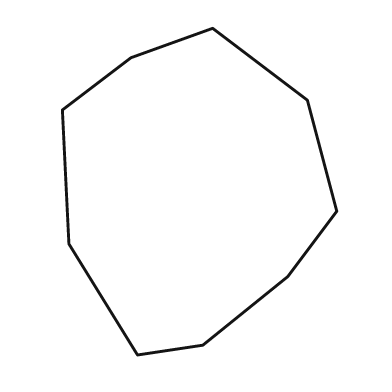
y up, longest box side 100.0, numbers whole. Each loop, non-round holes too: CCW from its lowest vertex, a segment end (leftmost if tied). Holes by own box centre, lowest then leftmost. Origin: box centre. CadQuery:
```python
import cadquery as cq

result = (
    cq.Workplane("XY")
    .moveTo(-19.0, -50.0)
    .lineTo(1.0, -47.0)
    .lineTo(27.0, -26.0)
    .lineTo(42.0, -6.0)
    .lineTo(33.0, 28.0)
    .lineTo(4.0, 50.0)
    .lineTo(-21.0, 41.0)
    .lineTo(-42.0, 25.0)
    .lineTo(-40.0, -16.0)
    .close()
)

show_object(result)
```